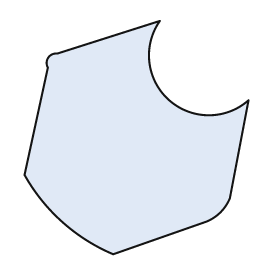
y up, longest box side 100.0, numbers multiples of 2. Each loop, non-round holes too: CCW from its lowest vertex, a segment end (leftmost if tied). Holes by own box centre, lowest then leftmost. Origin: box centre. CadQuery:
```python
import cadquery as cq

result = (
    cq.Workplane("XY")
    .moveTo(-10.0, -50.0)
    .lineTo(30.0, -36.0)
    .threePointArc((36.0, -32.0), (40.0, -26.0))
    .lineTo(48.0, 16.0)
    .threePointArc((14.0, 16.0), (10.0, 50.0))
    .lineTo(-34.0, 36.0)
    .threePointArc((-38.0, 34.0), (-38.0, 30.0))
    .lineTo(-48.0, -16.0)
    .threePointArc((-32.0, -36.0), (-10.0, -50.0))
    .close()
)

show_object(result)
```